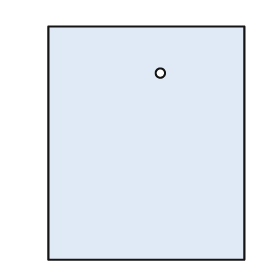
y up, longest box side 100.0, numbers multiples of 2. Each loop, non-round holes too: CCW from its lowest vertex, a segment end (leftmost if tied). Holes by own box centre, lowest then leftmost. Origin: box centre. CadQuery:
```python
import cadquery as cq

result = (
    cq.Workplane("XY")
    .moveTo(-42.0, -50.0)
    .lineTo(42.0, -50.0)
    .lineTo(42.0, 50.0)
    .lineTo(-42.0, 50.0)
    .close()
    .moveTo(6.0, 30.0)
    .circle(2.0)
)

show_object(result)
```